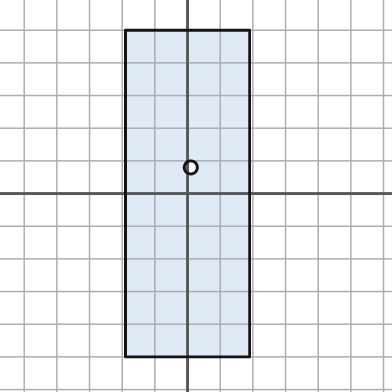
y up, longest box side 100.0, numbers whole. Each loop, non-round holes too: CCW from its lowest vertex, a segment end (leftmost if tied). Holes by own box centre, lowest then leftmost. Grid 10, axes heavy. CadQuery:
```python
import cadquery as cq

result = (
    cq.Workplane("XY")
    .moveTo(-19.0, -50.0)
    .lineTo(19.0, -50.0)
    .lineTo(19.0, 50.0)
    .lineTo(-19.0, 50.0)
    .close()
    .moveTo(1.0, 8.0)
    .circle(2.0)
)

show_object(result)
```